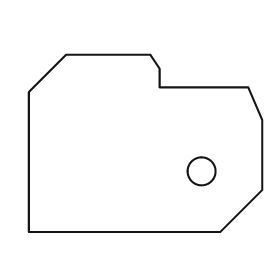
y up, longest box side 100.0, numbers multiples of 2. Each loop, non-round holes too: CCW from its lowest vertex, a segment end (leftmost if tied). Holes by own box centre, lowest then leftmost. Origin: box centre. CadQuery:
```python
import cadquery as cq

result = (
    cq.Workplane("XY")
    .moveTo(-50.0, -38.0)
    .lineTo(32.0, -38.0)
    .lineTo(50.0, -20.0)
    .lineTo(50.0, 10.0)
    .lineTo(44.0, 24.0)
    .lineTo(6.0, 24.0)
    .lineTo(6.0, 32.0)
    .lineTo(2.0, 38.0)
    .lineTo(-34.0, 38.0)
    .lineTo(-50.0, 22.0)
    .close()
    .moveTo(24.0, -12.0)
    .circle(6.0)
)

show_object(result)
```